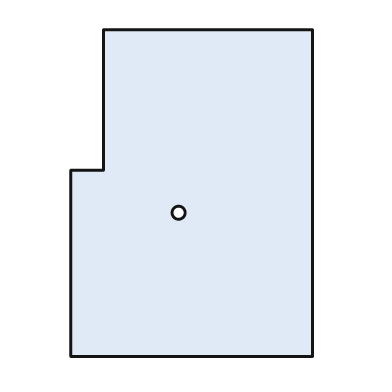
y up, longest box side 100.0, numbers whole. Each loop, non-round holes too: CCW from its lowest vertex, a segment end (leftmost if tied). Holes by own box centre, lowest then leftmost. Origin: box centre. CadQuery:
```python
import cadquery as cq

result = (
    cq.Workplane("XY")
    .moveTo(-37.0, -50.0)
    .lineTo(37.0, -50.0)
    .lineTo(37.0, 50.0)
    .lineTo(-27.0, 50.0)
    .lineTo(-27.0, 7.0)
    .lineTo(-37.0, 7.0)
    .close()
    .moveTo(-4.0, -6.0)
    .circle(2.0)
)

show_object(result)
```